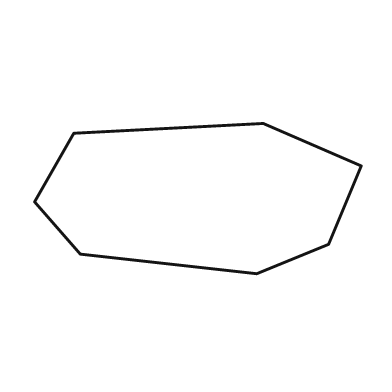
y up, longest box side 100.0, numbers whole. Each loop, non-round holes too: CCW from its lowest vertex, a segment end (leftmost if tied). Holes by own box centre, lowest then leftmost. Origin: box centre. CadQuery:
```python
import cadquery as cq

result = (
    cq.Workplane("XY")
    .moveTo(18.0, -23.0)
    .lineTo(40.0, -14.0)
    .lineTo(50.0, 10.0)
    .lineTo(20.0, 23.0)
    .lineTo(-38.0, 20.0)
    .lineTo(-50.0, -1.0)
    .lineTo(-36.0, -17.0)
    .close()
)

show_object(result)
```